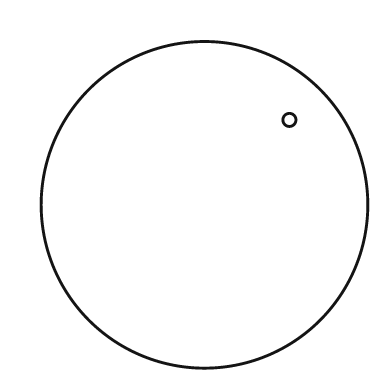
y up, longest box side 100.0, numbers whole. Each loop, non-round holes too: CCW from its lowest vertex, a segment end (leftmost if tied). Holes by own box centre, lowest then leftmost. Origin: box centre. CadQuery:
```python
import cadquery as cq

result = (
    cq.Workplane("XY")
    .moveTo(0.0, 0.0)
    .circle(50.0)
    .moveTo(26.0, 26.0)
    .circle(2.0)
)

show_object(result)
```